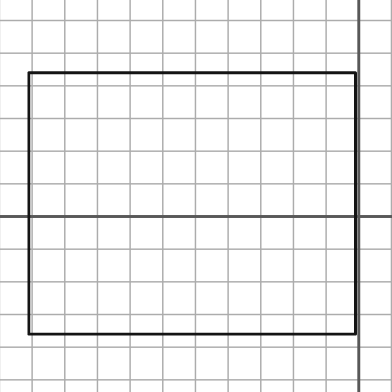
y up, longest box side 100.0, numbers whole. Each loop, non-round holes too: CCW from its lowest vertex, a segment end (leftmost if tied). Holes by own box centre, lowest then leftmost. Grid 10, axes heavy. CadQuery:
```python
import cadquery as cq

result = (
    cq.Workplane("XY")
    .moveTo(-101.0, -36.0)
    .lineTo(-1.0, -36.0)
    .lineTo(-1.0, 44.0)
    .lineTo(-101.0, 44.0)
    .close()
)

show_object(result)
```